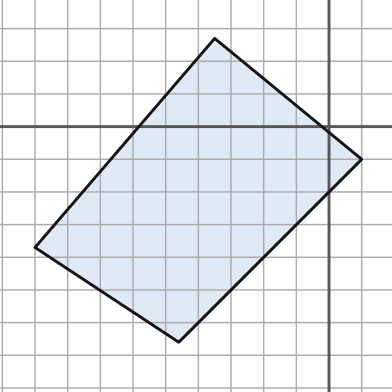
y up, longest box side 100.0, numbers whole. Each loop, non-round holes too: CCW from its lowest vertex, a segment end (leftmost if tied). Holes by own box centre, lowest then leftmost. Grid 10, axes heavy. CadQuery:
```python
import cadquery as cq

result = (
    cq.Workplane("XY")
    .moveTo(-46.0, -66.0)
    .lineTo(10.0, -10.0)
    .lineTo(-35.0, 27.0)
    .lineTo(-90.0, -37.0)
    .close()
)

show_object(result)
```